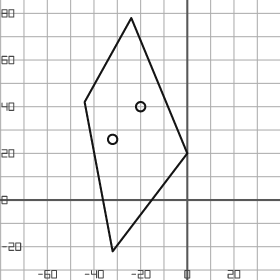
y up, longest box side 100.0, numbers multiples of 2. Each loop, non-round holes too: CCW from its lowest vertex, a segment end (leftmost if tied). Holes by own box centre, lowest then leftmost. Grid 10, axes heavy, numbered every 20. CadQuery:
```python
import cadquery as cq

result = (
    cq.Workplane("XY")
    .moveTo(-32.0, -22.0)
    .lineTo(0.0, 20.0)
    .lineTo(-24.0, 78.0)
    .lineTo(-44.0, 42.0)
    .close()
    .moveTo(-32.0, 26.0)
    .circle(2.0)
    .moveTo(-20.0, 40.0)
    .circle(2.0)
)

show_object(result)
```